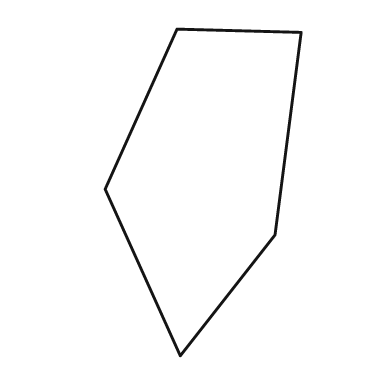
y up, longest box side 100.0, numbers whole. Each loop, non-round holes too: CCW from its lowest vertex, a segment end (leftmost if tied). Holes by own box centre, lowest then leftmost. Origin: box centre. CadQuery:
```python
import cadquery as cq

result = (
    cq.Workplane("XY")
    .moveTo(-7.0, -50.0)
    .lineTo(22.0, -13.0)
    .lineTo(30.0, 49.0)
    .lineTo(-8.0, 50.0)
    .lineTo(-30.0, 1.0)
    .close()
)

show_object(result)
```